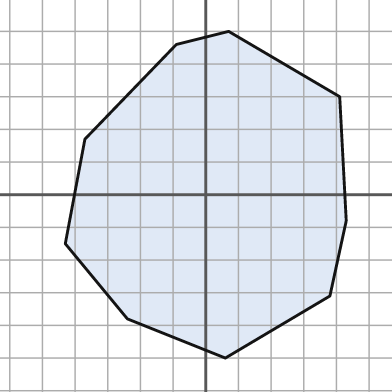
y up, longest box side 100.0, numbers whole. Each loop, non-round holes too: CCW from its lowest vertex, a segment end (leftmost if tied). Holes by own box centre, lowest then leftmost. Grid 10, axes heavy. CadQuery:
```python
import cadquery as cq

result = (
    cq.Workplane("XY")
    .moveTo(6.0, -50.0)
    .lineTo(38.0, -31.0)
    .lineTo(43.0, -8.0)
    .lineTo(41.0, 30.0)
    .lineTo(7.0, 50.0)
    .lineTo(-9.0, 46.0)
    .lineTo(-37.0, 17.0)
    .lineTo(-43.0, -15.0)
    .lineTo(-24.0, -38.0)
    .close()
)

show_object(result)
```